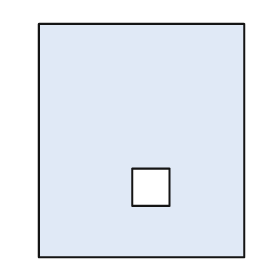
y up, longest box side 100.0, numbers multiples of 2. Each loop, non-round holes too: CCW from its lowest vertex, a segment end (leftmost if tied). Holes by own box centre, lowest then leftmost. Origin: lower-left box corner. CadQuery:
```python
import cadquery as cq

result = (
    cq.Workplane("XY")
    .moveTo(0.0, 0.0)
    .lineTo(88.0, 0.0)
    .lineTo(88.0, 100.0)
    .lineTo(0.0, 100.0)
    .close()
    .moveTo(40.0, 22.0)
    .lineTo(56.0, 22.0)
    .lineTo(56.0, 38.0)
    .lineTo(40.0, 38.0)
    .close()
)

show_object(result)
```